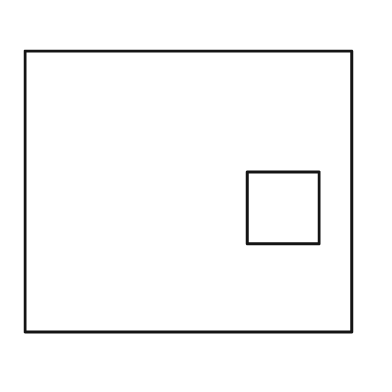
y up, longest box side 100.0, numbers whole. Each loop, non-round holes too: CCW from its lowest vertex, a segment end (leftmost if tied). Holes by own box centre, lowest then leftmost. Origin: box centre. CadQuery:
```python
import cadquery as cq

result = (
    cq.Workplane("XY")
    .moveTo(-50.0, -43.0)
    .lineTo(50.0, -43.0)
    .lineTo(50.0, 43.0)
    .lineTo(-50.0, 43.0)
    .close()
    .moveTo(18.0, -16.0)
    .lineTo(40.0, -16.0)
    .lineTo(40.0, 6.0)
    .lineTo(18.0, 6.0)
    .close()
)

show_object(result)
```